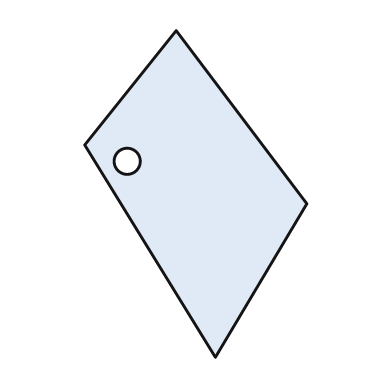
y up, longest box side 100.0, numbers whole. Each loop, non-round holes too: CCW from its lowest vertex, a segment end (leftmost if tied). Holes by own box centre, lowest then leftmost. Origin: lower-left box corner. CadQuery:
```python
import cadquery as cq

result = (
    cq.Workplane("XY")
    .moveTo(40.0, 0.0)
    .lineTo(68.0, 47.0)
    .lineTo(28.0, 100.0)
    .lineTo(0.0, 65.0)
    .close()
    .moveTo(13.0, 60.0)
    .circle(4.0)
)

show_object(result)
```